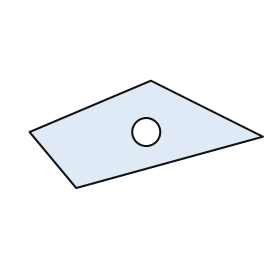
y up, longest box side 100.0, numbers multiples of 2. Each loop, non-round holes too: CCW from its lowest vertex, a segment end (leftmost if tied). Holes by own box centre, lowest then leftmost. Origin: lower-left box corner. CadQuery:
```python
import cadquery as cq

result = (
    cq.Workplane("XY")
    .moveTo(20.0, 0.0)
    .lineTo(100.0, 22.0)
    .lineTo(52.0, 46.0)
    .lineTo(0.0, 24.0)
    .close()
    .moveTo(50.0, 24.0)
    .circle(6.0)
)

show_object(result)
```